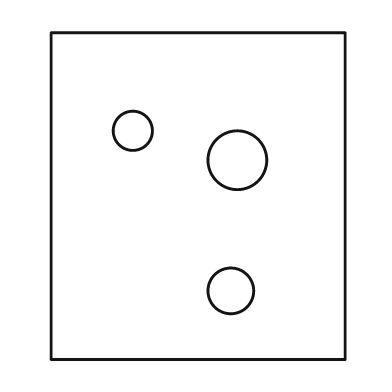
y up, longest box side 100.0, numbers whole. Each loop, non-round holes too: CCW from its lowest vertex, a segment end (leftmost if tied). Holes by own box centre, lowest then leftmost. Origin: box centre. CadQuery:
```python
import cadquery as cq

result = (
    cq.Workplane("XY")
    .moveTo(-45.0, -50.0)
    .lineTo(45.0, -50.0)
    .lineTo(45.0, 50.0)
    .lineTo(-45.0, 50.0)
    .close()
    .moveTo(10.0, -29.0)
    .circle(7.0)
    .moveTo(12.0, 11.0)
    .circle(9.0)
    .moveTo(-20.0, 20.0)
    .circle(6.0)
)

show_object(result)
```